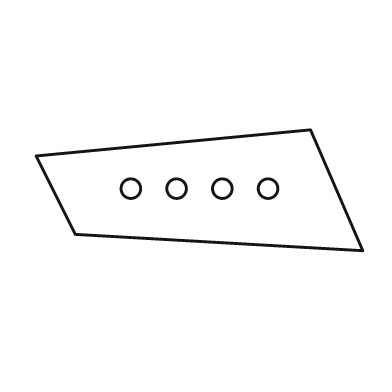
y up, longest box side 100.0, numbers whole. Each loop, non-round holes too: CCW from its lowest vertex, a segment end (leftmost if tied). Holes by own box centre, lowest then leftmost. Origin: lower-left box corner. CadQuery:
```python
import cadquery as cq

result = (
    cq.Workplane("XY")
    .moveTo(100.0, 0.0)
    .lineTo(84.0, 37.0)
    .lineTo(0.0, 29.0)
    .lineTo(12.0, 5.0)
    .close()
    .moveTo(29.0, 19.0)
    .circle(3.0)
    .moveTo(43.0, 19.0)
    .circle(3.0)
    .moveTo(57.0, 19.0)
    .circle(3.0)
    .moveTo(71.0, 19.0)
    .circle(3.0)
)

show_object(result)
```